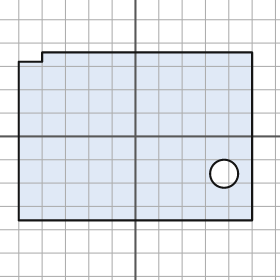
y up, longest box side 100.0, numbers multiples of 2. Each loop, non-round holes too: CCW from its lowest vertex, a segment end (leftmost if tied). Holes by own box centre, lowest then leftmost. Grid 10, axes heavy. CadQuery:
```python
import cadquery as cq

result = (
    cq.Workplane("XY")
    .moveTo(-50.0, -36.0)
    .lineTo(50.0, -36.0)
    .lineTo(50.0, 36.0)
    .lineTo(-40.0, 36.0)
    .lineTo(-40.0, 32.0)
    .lineTo(-50.0, 32.0)
    .close()
    .moveTo(38.0, -16.0)
    .circle(6.0)
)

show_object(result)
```